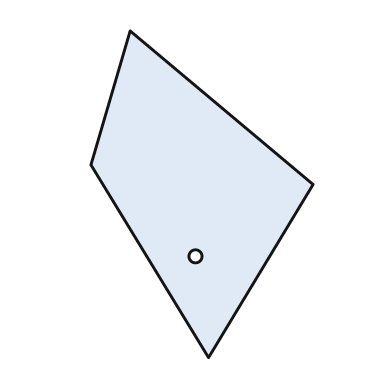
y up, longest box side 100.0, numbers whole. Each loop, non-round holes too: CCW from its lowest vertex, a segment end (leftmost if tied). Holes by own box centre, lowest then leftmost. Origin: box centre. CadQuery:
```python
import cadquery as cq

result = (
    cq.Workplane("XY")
    .moveTo(2.0, -50.0)
    .lineTo(34.0, 3.0)
    .lineTo(-22.0, 50.0)
    .lineTo(-34.0, 9.0)
    .close()
    .moveTo(-2.0, -19.0)
    .circle(2.0)
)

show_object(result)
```